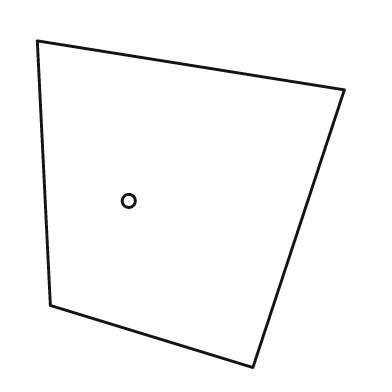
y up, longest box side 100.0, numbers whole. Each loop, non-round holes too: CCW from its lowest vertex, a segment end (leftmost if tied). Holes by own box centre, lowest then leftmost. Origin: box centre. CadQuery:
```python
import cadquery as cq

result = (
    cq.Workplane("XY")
    .moveTo(19.0, -50.0)
    .lineTo(47.0, 35.0)
    .lineTo(-47.0, 50.0)
    .lineTo(-43.0, -31.0)
    .close()
    .moveTo(-19.0, 1.0)
    .circle(2.0)
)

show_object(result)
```